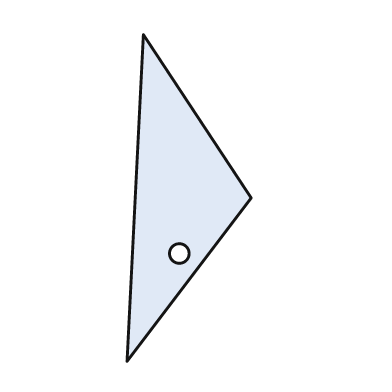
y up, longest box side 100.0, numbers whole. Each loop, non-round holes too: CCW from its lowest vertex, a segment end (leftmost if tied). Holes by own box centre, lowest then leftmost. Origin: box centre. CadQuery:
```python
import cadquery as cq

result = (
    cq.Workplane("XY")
    .moveTo(-19.0, -50.0)
    .lineTo(19.0, 0.0)
    .lineTo(-14.0, 50.0)
    .close()
    .moveTo(-3.0, -17.0)
    .circle(3.0)
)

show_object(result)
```